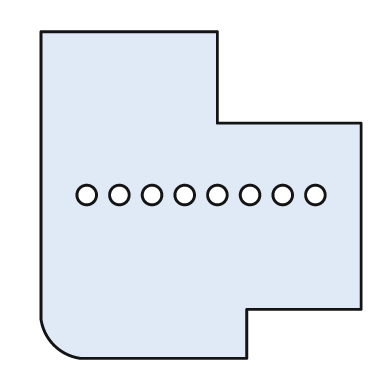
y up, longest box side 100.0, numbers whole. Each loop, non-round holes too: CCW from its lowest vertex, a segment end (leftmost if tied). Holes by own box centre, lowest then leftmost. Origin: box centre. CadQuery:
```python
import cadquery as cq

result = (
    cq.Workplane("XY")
    .moveTo(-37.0, -50.0)
    .lineTo(14.0, -50.0)
    .lineTo(14.0, -35.0)
    .lineTo(49.0, -35.0)
    .lineTo(49.0, 22.0)
    .lineTo(5.0, 22.0)
    .lineTo(5.0, 50.0)
    .lineTo(-49.0, 50.0)
    .lineTo(-49.0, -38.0)
    .threePointArc((-45.0, -46.0), (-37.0, -50.0))
    .close()
    .moveTo(-35.0, 0.0)
    .circle(3.0)
    .moveTo(-25.0, 0.0)
    .circle(3.0)
    .moveTo(-15.0, 0.0)
    .circle(3.0)
    .moveTo(-5.0, 0.0)
    .circle(3.0)
    .moveTo(5.0, 0.0)
    .circle(3.0)
    .moveTo(15.0, 0.0)
    .circle(3.0)
    .moveTo(25.0, 0.0)
    .circle(3.0)
    .moveTo(35.0, 0.0)
    .circle(3.0)
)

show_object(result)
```